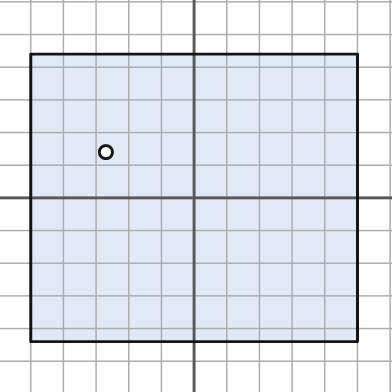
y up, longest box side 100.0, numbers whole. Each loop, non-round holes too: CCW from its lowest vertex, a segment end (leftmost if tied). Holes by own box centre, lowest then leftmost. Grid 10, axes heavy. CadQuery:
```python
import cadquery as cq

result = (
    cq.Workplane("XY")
    .moveTo(-50.0, -44.0)
    .lineTo(50.0, -44.0)
    .lineTo(50.0, 44.0)
    .lineTo(-50.0, 44.0)
    .close()
    .moveTo(-27.0, 14.0)
    .circle(2.0)
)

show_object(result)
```